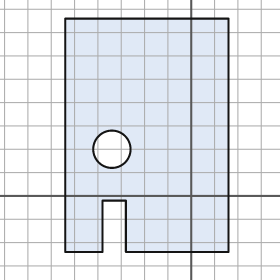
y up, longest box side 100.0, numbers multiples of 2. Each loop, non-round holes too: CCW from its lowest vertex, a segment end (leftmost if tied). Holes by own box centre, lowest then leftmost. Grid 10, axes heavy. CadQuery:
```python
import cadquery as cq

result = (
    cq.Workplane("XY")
    .moveTo(-54.0, -24.0)
    .lineTo(-38.0, -24.0)
    .lineTo(-38.0, -2.0)
    .lineTo(-28.0, -2.0)
    .lineTo(-28.0, -24.0)
    .lineTo(16.0, -24.0)
    .lineTo(16.0, 76.0)
    .lineTo(-54.0, 76.0)
    .close()
    .moveTo(-34.0, 20.0)
    .circle(8.0)
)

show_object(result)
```